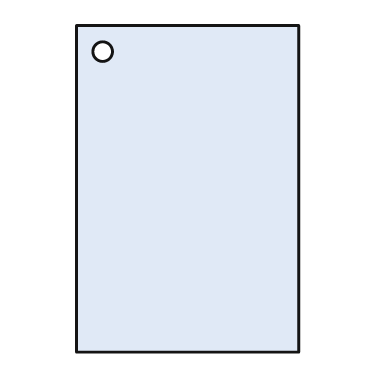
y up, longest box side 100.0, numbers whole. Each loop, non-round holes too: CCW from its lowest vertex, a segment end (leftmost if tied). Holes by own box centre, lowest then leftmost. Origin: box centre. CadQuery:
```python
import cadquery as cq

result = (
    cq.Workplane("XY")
    .moveTo(-34.0, -50.0)
    .lineTo(34.0, -50.0)
    .lineTo(34.0, 50.0)
    .lineTo(-34.0, 50.0)
    .close()
    .moveTo(-26.0, 42.0)
    .circle(3.0)
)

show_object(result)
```